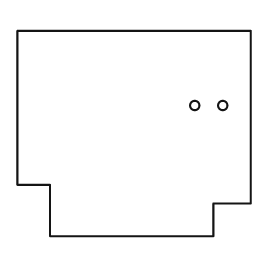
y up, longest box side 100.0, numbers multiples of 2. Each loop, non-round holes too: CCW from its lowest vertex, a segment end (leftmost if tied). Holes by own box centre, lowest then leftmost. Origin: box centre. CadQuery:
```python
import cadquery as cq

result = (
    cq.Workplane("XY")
    .moveTo(-36.0, -44.0)
    .lineTo(34.0, -44.0)
    .lineTo(34.0, -30.0)
    .lineTo(50.0, -30.0)
    .lineTo(50.0, 44.0)
    .lineTo(-50.0, 44.0)
    .lineTo(-50.0, -22.0)
    .lineTo(-36.0, -22.0)
    .close()
    .moveTo(26.0, 12.0)
    .circle(2.0)
    .moveTo(38.0, 12.0)
    .circle(2.0)
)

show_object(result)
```